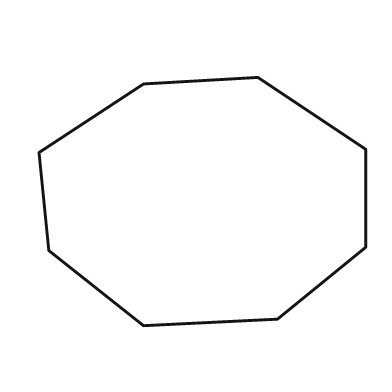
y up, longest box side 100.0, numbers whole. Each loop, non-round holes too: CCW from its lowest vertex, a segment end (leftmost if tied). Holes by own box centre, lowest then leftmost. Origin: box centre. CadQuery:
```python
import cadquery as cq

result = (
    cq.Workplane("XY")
    .moveTo(-18.0, -38.0)
    .lineTo(23.0, -36.0)
    .lineTo(50.0, -14.0)
    .lineTo(50.0, 16.0)
    .lineTo(17.0, 38.0)
    .lineTo(-18.0, 36.0)
    .lineTo(-50.0, 15.0)
    .lineTo(-47.0, -15.0)
    .close()
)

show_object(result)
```